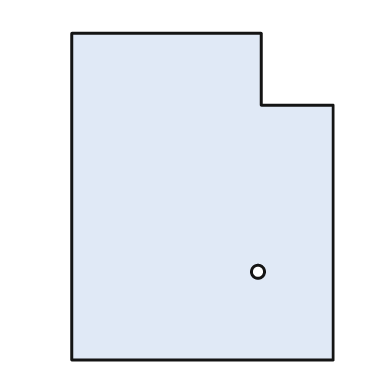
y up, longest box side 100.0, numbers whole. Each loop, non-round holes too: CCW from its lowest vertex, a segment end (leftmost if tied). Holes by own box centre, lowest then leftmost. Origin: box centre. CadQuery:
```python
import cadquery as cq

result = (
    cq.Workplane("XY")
    .moveTo(-40.0, -50.0)
    .lineTo(40.0, -50.0)
    .lineTo(40.0, 28.0)
    .lineTo(18.0, 28.0)
    .lineTo(18.0, 50.0)
    .lineTo(-40.0, 50.0)
    .close()
    .moveTo(17.0, -23.0)
    .circle(2.0)
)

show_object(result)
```